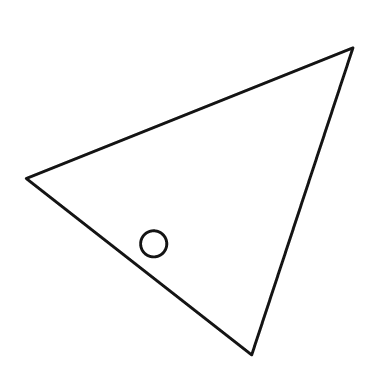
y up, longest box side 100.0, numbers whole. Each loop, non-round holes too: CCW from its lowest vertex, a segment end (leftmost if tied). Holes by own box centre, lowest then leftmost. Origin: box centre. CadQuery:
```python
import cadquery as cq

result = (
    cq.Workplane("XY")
    .moveTo(19.0, -47.0)
    .lineTo(50.0, 47.0)
    .lineTo(-50.0, 7.0)
    .close()
    .moveTo(-11.0, -13.0)
    .circle(4.0)
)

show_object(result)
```